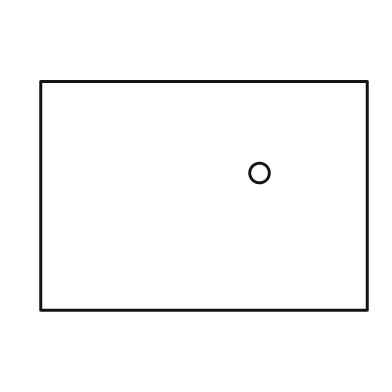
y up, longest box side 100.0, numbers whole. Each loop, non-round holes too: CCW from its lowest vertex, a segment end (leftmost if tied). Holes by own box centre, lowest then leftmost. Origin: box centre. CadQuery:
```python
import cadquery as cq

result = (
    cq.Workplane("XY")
    .moveTo(-50.0, -35.0)
    .lineTo(50.0, -35.0)
    .lineTo(50.0, 35.0)
    .lineTo(-50.0, 35.0)
    .close()
    .moveTo(17.0, 7.0)
    .circle(3.0)
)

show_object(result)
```